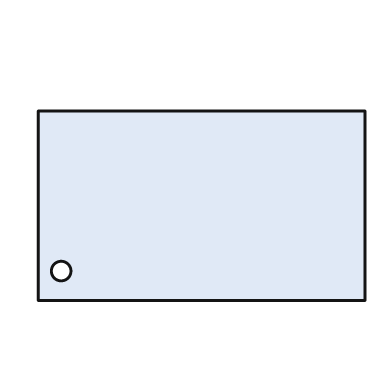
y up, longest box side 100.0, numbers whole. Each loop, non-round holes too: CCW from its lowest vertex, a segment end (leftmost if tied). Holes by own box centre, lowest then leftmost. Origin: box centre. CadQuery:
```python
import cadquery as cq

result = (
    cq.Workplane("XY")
    .moveTo(-50.0, -29.0)
    .lineTo(50.0, -29.0)
    .lineTo(50.0, 29.0)
    .lineTo(-50.0, 29.0)
    .close()
    .moveTo(-43.0, -20.0)
    .circle(3.0)
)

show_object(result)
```